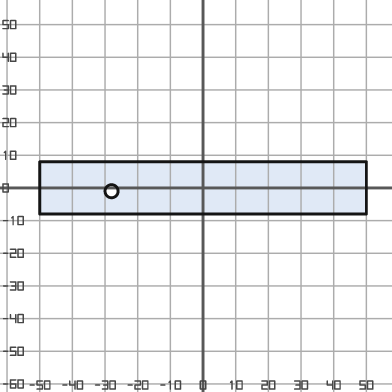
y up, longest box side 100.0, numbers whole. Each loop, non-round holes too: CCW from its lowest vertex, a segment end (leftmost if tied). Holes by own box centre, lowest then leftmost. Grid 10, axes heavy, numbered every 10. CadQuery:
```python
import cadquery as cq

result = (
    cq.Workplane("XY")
    .moveTo(-50.0, -8.0)
    .lineTo(50.0, -8.0)
    .lineTo(50.0, 8.0)
    .lineTo(-50.0, 8.0)
    .close()
    .moveTo(-28.0, -1.0)
    .circle(2.0)
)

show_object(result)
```